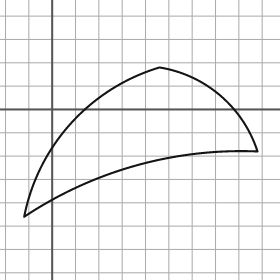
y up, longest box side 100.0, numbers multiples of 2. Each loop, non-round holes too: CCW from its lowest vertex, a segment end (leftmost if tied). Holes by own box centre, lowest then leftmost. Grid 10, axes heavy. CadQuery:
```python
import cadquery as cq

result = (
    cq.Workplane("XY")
    .moveTo(-12.0, -46.0)
    .threePointArc((36.0, -24.0), (88.0, -18.0))
    .threePointArc((72.0, 6.0), (46.0, 18.0))
    .threePointArc((8.0, -6.0), (-12.0, -46.0))
    .close()
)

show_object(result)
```